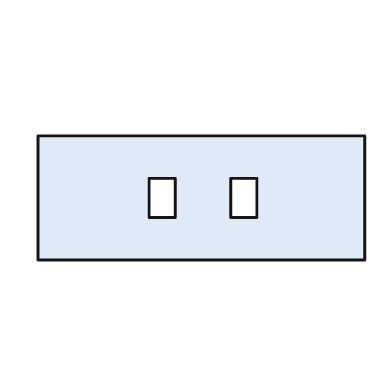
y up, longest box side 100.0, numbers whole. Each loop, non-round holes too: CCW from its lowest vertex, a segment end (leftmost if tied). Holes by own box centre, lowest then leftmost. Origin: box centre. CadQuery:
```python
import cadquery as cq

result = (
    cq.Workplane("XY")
    .moveTo(-50.0, -19.0)
    .lineTo(50.0, -19.0)
    .lineTo(50.0, 19.0)
    .lineTo(-50.0, 19.0)
    .close()
    .moveTo(-16.0, -6.0)
    .lineTo(-8.0, -6.0)
    .lineTo(-8.0, 6.0)
    .lineTo(-16.0, 6.0)
    .close()
    .moveTo(9.0, -6.0)
    .lineTo(17.0, -6.0)
    .lineTo(17.0, 6.0)
    .lineTo(9.0, 6.0)
    .close()
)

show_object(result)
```